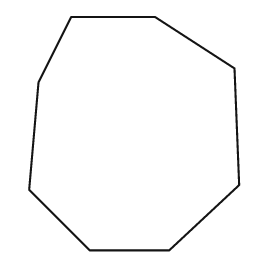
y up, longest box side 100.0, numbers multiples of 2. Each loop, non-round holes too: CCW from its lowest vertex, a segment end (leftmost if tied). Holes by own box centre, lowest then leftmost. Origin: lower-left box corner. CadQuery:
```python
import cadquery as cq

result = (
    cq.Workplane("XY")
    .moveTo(26.0, 0.0)
    .lineTo(60.0, 0.0)
    .lineTo(90.0, 28.0)
    .lineTo(88.0, 78.0)
    .lineTo(54.0, 100.0)
    .lineTo(18.0, 100.0)
    .lineTo(4.0, 72.0)
    .lineTo(0.0, 26.0)
    .close()
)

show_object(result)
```